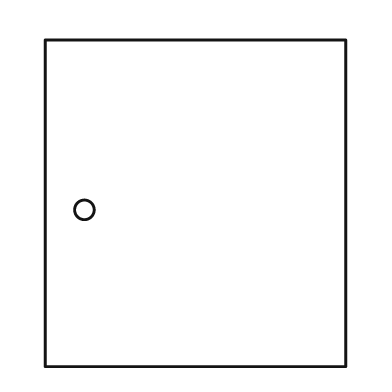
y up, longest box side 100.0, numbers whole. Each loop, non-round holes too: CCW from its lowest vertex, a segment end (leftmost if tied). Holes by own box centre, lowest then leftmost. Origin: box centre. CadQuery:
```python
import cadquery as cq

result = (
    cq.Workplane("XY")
    .moveTo(-46.0, -50.0)
    .lineTo(46.0, -50.0)
    .lineTo(46.0, 50.0)
    .lineTo(-46.0, 50.0)
    .close()
    .moveTo(-34.0, -2.0)
    .circle(3.0)
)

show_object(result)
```